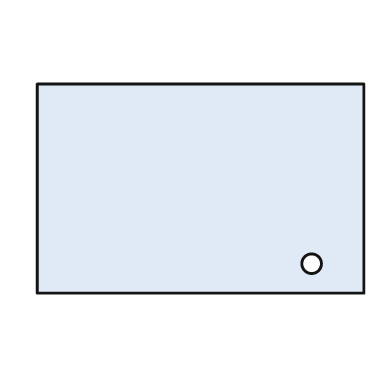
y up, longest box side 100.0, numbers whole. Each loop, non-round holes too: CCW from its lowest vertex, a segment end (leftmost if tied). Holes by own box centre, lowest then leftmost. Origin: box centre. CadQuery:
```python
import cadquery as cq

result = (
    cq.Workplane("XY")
    .moveTo(-50.0, -32.0)
    .lineTo(50.0, -32.0)
    .lineTo(50.0, 32.0)
    .lineTo(-50.0, 32.0)
    .close()
    .moveTo(34.0, -23.0)
    .circle(3.0)
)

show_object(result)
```